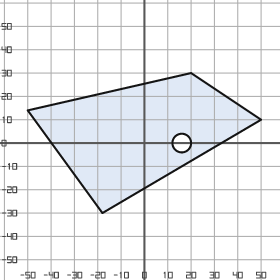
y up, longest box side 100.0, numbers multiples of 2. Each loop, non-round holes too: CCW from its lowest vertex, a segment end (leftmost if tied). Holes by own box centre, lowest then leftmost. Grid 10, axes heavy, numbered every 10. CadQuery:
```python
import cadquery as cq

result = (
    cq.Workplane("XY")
    .moveTo(-18.0, -30.0)
    .lineTo(50.0, 10.0)
    .lineTo(20.0, 30.0)
    .lineTo(-50.0, 14.0)
    .close()
    .moveTo(16.0, 0.0)
    .circle(4.0)
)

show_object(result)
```